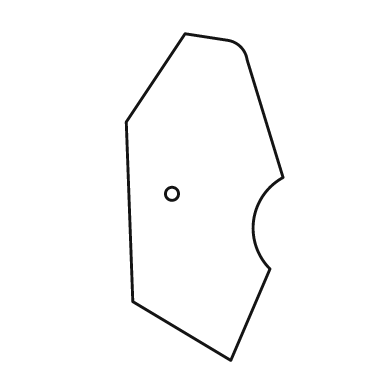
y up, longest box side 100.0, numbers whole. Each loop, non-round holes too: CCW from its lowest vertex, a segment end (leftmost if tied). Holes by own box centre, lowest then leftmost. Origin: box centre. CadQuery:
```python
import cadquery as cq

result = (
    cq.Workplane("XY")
    .moveTo(8.0, -50.0)
    .lineTo(20.0, -22.0)
    .threePointArc((15.0, -7.0), (24.0, 6.0))
    .lineTo(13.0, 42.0)
    .threePointArc((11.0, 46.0), (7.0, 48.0))
    .lineTo(-6.0, 50.0)
    .lineTo(-24.0, 23.0)
    .lineTo(-22.0, -32.0)
    .close()
    .moveTo(-10.0, 1.0)
    .circle(2.0)
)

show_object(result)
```